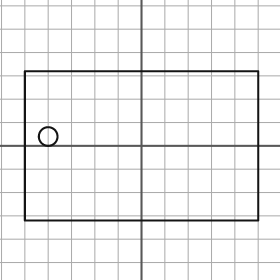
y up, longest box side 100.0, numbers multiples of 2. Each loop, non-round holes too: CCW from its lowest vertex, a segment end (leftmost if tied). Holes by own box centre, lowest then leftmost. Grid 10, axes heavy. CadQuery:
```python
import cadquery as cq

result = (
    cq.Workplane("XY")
    .moveTo(-50.0, -32.0)
    .lineTo(50.0, -32.0)
    .lineTo(50.0, 32.0)
    .lineTo(-50.0, 32.0)
    .close()
    .moveTo(-40.0, 4.0)
    .circle(4.0)
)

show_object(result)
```